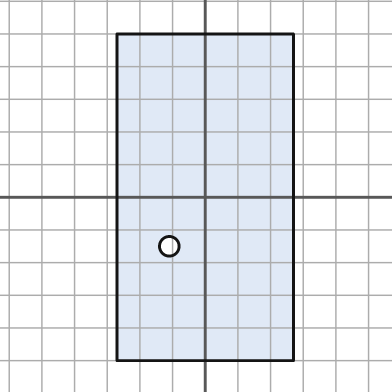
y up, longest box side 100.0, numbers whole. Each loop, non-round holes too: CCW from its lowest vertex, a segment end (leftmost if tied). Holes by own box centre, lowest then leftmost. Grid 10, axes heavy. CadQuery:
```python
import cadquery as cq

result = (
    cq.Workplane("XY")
    .moveTo(-27.0, -50.0)
    .lineTo(27.0, -50.0)
    .lineTo(27.0, 50.0)
    .lineTo(-27.0, 50.0)
    .close()
    .moveTo(-11.0, -15.0)
    .circle(3.0)
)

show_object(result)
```